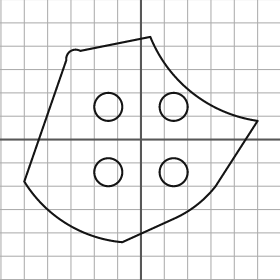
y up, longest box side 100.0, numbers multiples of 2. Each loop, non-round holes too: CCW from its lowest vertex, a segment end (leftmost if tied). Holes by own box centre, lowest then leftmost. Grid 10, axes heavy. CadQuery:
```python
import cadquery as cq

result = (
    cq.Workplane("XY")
    .moveTo(-8.0, -44.0)
    .lineTo(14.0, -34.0)
    .threePointArc((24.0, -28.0), (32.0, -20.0))
    .lineTo(50.0, 8.0)
    .threePointArc((22.0, 20.0), (4.0, 44.0))
    .lineTo(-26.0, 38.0)
    .threePointArc((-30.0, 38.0), (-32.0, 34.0))
    .lineTo(-50.0, -18.0)
    .threePointArc((-32.0, -36.0), (-8.0, -44.0))
    .close()
    .moveTo(-14.0, -14.0)
    .circle(6.0)
    .moveTo(14.0, -14.0)
    .circle(6.0)
    .moveTo(-14.0, 14.0)
    .circle(6.0)
    .moveTo(14.0, 14.0)
    .circle(6.0)
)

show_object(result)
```